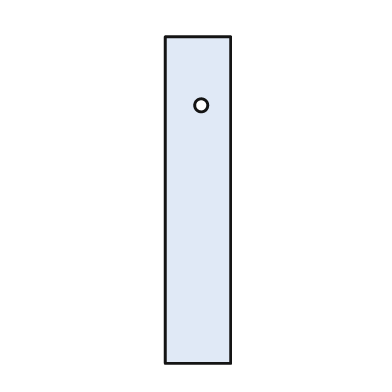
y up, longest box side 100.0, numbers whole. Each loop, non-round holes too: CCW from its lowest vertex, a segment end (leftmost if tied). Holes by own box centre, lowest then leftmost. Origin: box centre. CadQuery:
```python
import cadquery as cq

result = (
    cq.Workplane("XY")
    .moveTo(-10.0, -50.0)
    .lineTo(10.0, -50.0)
    .lineTo(10.0, 50.0)
    .lineTo(-10.0, 50.0)
    .close()
    .moveTo(1.0, 29.0)
    .circle(2.0)
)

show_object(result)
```